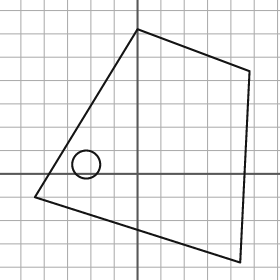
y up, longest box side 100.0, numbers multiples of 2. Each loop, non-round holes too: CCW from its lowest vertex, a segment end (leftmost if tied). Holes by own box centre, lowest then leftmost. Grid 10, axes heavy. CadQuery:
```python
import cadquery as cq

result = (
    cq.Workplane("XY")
    .moveTo(44.0, -38.0)
    .lineTo(48.0, 44.0)
    .lineTo(0.0, 62.0)
    .lineTo(-44.0, -10.0)
    .close()
    .moveTo(-22.0, 4.0)
    .circle(6.0)
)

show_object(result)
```